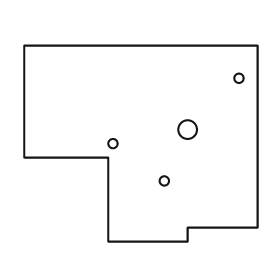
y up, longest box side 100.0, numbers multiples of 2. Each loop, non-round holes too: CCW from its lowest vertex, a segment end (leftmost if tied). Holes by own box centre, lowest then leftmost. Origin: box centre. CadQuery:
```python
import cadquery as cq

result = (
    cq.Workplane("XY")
    .moveTo(-14.0, -42.0)
    .lineTo(20.0, -42.0)
    .lineTo(20.0, -36.0)
    .lineTo(50.0, -36.0)
    .lineTo(50.0, 42.0)
    .lineTo(-50.0, 42.0)
    .lineTo(-50.0, -6.0)
    .lineTo(-14.0, -6.0)
    .close()
    .moveTo(10.0, -16.0)
    .circle(2.0)
    .moveTo(-12.0, 0.0)
    .circle(2.0)
    .moveTo(20.0, 6.0)
    .circle(4.0)
    .moveTo(42.0, 28.0)
    .circle(2.0)
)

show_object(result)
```